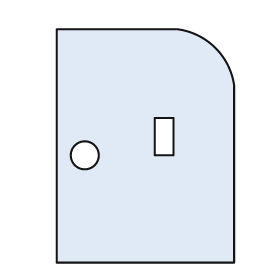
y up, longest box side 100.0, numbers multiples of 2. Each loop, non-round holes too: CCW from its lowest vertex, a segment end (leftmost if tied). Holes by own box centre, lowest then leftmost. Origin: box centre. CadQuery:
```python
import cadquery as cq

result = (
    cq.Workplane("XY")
    .moveTo(-38.0, -50.0)
    .lineTo(38.0, -50.0)
    .lineTo(38.0, 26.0)
    .threePointArc((30.0, 42.0), (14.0, 50.0))
    .lineTo(-38.0, 50.0)
    .close()
    .moveTo(-26.0, -4.0)
    .circle(6.0)
    .moveTo(4.0, -4.0)
    .lineTo(12.0, -4.0)
    .lineTo(12.0, 12.0)
    .lineTo(4.0, 12.0)
    .close()
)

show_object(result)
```